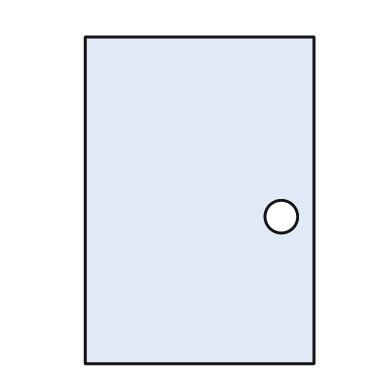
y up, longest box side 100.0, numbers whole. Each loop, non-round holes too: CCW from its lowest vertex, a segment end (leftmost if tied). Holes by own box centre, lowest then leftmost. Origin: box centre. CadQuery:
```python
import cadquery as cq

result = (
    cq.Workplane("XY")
    .moveTo(-35.0, -50.0)
    .lineTo(35.0, -50.0)
    .lineTo(35.0, 50.0)
    .lineTo(-35.0, 50.0)
    .close()
    .moveTo(25.0, -5.0)
    .circle(5.0)
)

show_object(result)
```